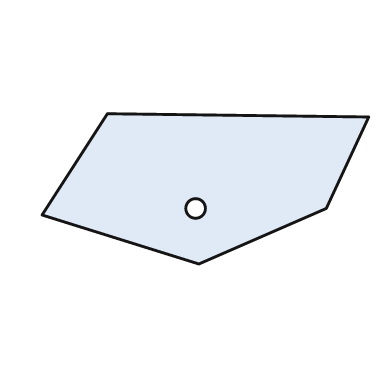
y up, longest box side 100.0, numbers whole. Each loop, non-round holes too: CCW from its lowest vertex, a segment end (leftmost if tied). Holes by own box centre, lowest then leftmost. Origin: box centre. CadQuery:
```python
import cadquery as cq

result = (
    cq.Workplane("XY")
    .moveTo(-2.0, -23.0)
    .lineTo(37.0, -6.0)
    .lineTo(50.0, 22.0)
    .lineTo(-30.0, 23.0)
    .lineTo(-50.0, -8.0)
    .close()
    .moveTo(-3.0, -6.0)
    .circle(3.0)
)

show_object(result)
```